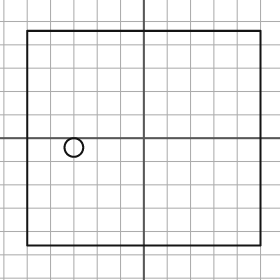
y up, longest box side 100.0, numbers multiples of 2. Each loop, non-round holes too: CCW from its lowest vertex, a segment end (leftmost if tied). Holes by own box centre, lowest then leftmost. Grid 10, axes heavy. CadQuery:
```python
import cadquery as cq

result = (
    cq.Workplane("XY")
    .moveTo(-50.0, -46.0)
    .lineTo(50.0, -46.0)
    .lineTo(50.0, 46.0)
    .lineTo(-50.0, 46.0)
    .close()
    .moveTo(-30.0, -4.0)
    .circle(4.0)
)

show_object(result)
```